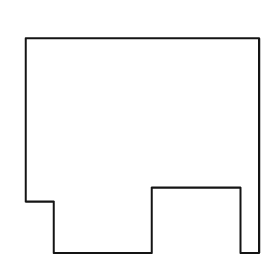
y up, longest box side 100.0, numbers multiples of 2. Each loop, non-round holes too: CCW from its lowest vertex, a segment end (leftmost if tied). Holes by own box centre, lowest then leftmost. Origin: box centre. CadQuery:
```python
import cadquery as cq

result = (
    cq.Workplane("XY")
    .moveTo(-38.0, -46.0)
    .lineTo(4.0, -46.0)
    .lineTo(4.0, -18.0)
    .lineTo(42.0, -18.0)
    .lineTo(42.0, -46.0)
    .lineTo(50.0, -46.0)
    .lineTo(50.0, 46.0)
    .lineTo(-50.0, 46.0)
    .lineTo(-50.0, -24.0)
    .lineTo(-38.0, -24.0)
    .close()
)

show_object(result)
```